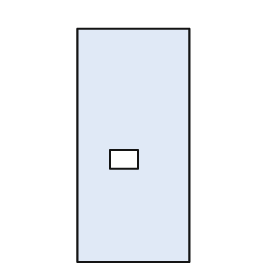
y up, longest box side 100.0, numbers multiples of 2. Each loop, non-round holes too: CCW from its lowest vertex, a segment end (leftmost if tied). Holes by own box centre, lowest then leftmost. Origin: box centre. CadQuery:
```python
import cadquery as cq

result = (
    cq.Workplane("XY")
    .moveTo(-24.0, -50.0)
    .lineTo(24.0, -50.0)
    .lineTo(24.0, 50.0)
    .lineTo(-24.0, 50.0)
    .close()
    .moveTo(-10.0, -10.0)
    .lineTo(2.0, -10.0)
    .lineTo(2.0, -2.0)
    .lineTo(-10.0, -2.0)
    .close()
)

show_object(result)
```